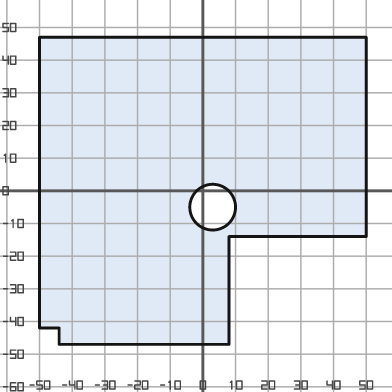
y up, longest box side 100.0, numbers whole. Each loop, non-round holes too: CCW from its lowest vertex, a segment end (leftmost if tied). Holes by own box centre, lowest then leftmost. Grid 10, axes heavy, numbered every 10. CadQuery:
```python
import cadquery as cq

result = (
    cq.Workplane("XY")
    .moveTo(-44.0, -47.0)
    .lineTo(8.0, -47.0)
    .lineTo(8.0, -14.0)
    .lineTo(50.0, -14.0)
    .lineTo(50.0, 47.0)
    .lineTo(-50.0, 47.0)
    .lineTo(-50.0, -42.0)
    .lineTo(-44.0, -42.0)
    .close()
    .moveTo(3.0, -5.0)
    .circle(7.0)
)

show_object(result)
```